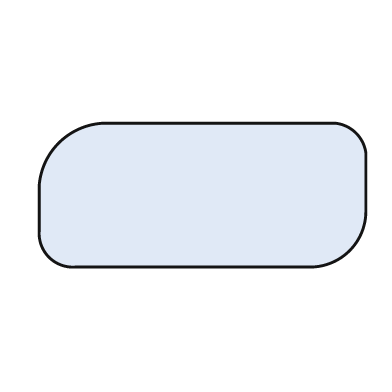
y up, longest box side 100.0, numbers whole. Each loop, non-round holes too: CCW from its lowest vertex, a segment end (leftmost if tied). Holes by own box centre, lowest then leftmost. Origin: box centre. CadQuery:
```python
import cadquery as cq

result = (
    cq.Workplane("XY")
    .moveTo(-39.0, -22.0)
    .lineTo(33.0, -22.0)
    .threePointArc((45.0, -17.0), (50.0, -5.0))
    .lineTo(50.0, 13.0)
    .threePointArc((47.0, 19.0), (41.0, 22.0))
    .lineTo(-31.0, 22.0)
    .threePointArc((-44.0, 16.0), (-50.0, 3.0))
    .lineTo(-50.0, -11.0)
    .threePointArc((-47.0, -19.0), (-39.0, -22.0))
    .close()
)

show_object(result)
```